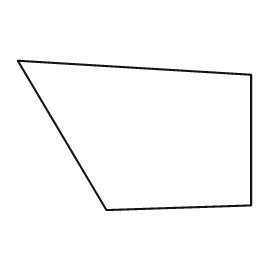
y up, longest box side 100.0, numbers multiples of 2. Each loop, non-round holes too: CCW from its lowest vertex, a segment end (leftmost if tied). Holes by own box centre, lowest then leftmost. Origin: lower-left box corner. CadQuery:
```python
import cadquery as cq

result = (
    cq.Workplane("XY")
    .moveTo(38.0, 0.0)
    .lineTo(100.0, 2.0)
    .lineTo(100.0, 58.0)
    .lineTo(0.0, 64.0)
    .close()
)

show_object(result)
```